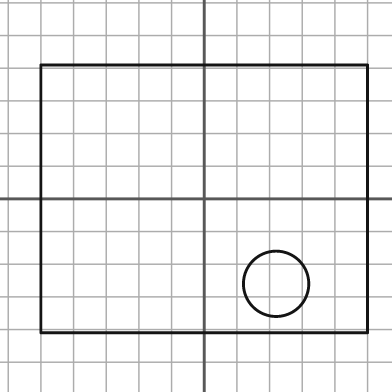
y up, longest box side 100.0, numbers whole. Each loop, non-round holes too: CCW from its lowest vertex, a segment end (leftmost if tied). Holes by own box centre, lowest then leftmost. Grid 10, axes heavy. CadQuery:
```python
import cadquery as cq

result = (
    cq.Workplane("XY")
    .moveTo(-50.0, -41.0)
    .lineTo(50.0, -41.0)
    .lineTo(50.0, 41.0)
    .lineTo(-50.0, 41.0)
    .close()
    .moveTo(22.0, -26.0)
    .circle(10.0)
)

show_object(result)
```